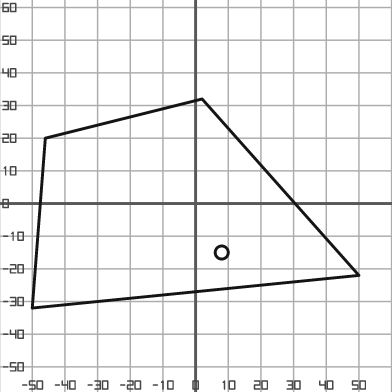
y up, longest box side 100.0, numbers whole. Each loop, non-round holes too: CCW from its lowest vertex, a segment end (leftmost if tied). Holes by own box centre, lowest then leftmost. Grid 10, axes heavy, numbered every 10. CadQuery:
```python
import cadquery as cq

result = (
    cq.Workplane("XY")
    .moveTo(-50.0, -32.0)
    .lineTo(50.0, -22.0)
    .lineTo(2.0, 32.0)
    .lineTo(-46.0, 20.0)
    .close()
    .moveTo(8.0, -15.0)
    .circle(2.0)
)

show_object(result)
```